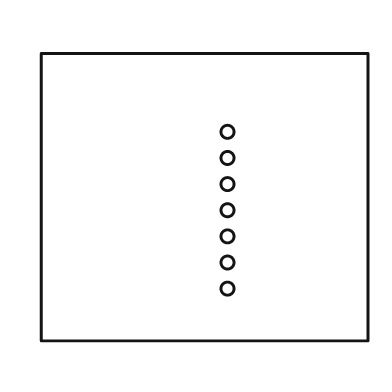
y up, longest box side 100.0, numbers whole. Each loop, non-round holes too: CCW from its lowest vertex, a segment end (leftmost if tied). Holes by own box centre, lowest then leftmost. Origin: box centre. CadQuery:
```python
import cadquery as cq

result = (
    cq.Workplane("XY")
    .moveTo(-50.0, -44.0)
    .lineTo(50.0, -44.0)
    .lineTo(50.0, 44.0)
    .lineTo(-50.0, 44.0)
    .close()
    .moveTo(7.0, -28.0)
    .circle(2.0)
    .moveTo(7.0, -20.0)
    .circle(2.0)
    .moveTo(7.0, -12.0)
    .circle(2.0)
    .moveTo(7.0, -4.0)
    .circle(2.0)
    .moveTo(7.0, 4.0)
    .circle(2.0)
    .moveTo(7.0, 12.0)
    .circle(2.0)
    .moveTo(7.0, 20.0)
    .circle(2.0)
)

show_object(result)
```